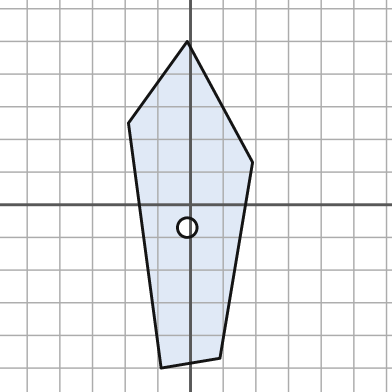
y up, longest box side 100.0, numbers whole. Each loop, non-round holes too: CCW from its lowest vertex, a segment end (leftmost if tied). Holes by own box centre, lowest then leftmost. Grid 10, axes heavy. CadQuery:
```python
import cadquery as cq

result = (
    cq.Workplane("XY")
    .moveTo(-9.0, -50.0)
    .lineTo(9.0, -47.0)
    .lineTo(19.0, 13.0)
    .lineTo(-1.0, 50.0)
    .lineTo(-19.0, 25.0)
    .close()
    .moveTo(-1.0, -7.0)
    .circle(3.0)
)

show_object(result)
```